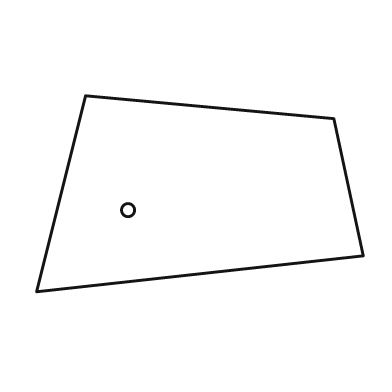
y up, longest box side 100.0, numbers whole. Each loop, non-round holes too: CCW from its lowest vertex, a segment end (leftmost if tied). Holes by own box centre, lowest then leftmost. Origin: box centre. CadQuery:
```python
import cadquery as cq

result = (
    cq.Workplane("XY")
    .moveTo(-50.0, -30.0)
    .lineTo(50.0, -19.0)
    .lineTo(41.0, 23.0)
    .lineTo(-35.0, 30.0)
    .close()
    .moveTo(-22.0, -5.0)
    .circle(2.0)
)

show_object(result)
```